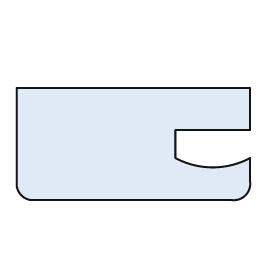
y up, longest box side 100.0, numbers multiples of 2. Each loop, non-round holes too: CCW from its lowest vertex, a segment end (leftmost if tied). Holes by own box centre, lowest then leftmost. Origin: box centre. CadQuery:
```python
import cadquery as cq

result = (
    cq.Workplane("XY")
    .moveTo(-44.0, -24.0)
    .lineTo(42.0, -24.0)
    .threePointArc((48.0, -22.0), (50.0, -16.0))
    .lineTo(50.0, -6.0)
    .threePointArc((34.0, -10.0), (18.0, -6.0))
    .lineTo(18.0, 6.0)
    .lineTo(50.0, 6.0)
    .lineTo(50.0, 24.0)
    .lineTo(-50.0, 24.0)
    .lineTo(-50.0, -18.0)
    .threePointArc((-48.0, -22.0), (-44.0, -24.0))
    .close()
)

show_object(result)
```